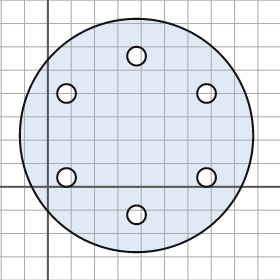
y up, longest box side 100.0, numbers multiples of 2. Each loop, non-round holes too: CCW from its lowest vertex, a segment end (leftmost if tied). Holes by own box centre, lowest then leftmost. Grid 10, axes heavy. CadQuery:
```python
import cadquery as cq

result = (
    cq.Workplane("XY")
    .moveTo(38.0, 22.0)
    .circle(50.0)
    .moveTo(38.0, -12.0)
    .circle(4.0)
    .moveTo(8.0, 4.0)
    .circle(4.0)
    .moveTo(68.0, 4.0)
    .circle(4.0)
    .moveTo(8.0, 40.0)
    .circle(4.0)
    .moveTo(68.0, 40.0)
    .circle(4.0)
    .moveTo(38.0, 56.0)
    .circle(4.0)
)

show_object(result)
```